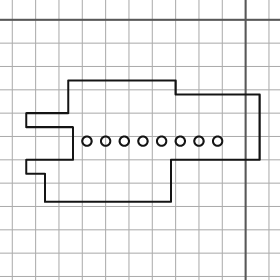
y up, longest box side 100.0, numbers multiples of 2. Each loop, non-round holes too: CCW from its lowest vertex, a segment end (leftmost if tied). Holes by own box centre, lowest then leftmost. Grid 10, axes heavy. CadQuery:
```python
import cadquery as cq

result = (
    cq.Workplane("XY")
    .moveTo(-86.0, -78.0)
    .lineTo(-32.0, -78.0)
    .lineTo(-32.0, -60.0)
    .lineTo(6.0, -60.0)
    .lineTo(6.0, -32.0)
    .lineTo(-30.0, -32.0)
    .lineTo(-30.0, -26.0)
    .lineTo(-76.0, -26.0)
    .lineTo(-76.0, -40.0)
    .lineTo(-94.0, -40.0)
    .lineTo(-94.0, -46.0)
    .lineTo(-74.0, -46.0)
    .lineTo(-74.0, -60.0)
    .lineTo(-94.0, -60.0)
    .lineTo(-94.0, -66.0)
    .lineTo(-86.0, -66.0)
    .close()
    .moveTo(-68.0, -52.0)
    .circle(2.0)
    .moveTo(-60.0, -52.0)
    .circle(2.0)
    .moveTo(-52.0, -52.0)
    .circle(2.0)
    .moveTo(-44.0, -52.0)
    .circle(2.0)
    .moveTo(-36.0, -52.0)
    .circle(2.0)
    .moveTo(-28.0, -52.0)
    .circle(2.0)
    .moveTo(-20.0, -52.0)
    .circle(2.0)
    .moveTo(-12.0, -52.0)
    .circle(2.0)
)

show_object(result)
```